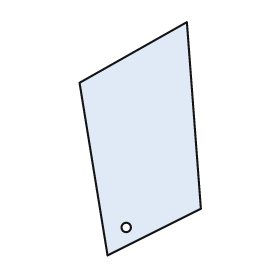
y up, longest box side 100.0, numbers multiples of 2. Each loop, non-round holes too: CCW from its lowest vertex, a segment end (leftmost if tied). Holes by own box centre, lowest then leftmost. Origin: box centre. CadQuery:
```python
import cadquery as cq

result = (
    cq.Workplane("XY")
    .moveTo(-14.0, -50.0)
    .lineTo(26.0, -30.0)
    .lineTo(20.0, 50.0)
    .lineTo(-26.0, 24.0)
    .close()
    .moveTo(-6.0, -38.0)
    .circle(2.0)
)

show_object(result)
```